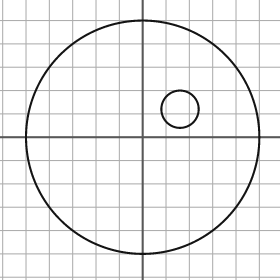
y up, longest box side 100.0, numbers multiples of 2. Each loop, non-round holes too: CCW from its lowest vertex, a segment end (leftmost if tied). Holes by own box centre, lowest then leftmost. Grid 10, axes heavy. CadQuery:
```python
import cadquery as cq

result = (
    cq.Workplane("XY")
    .moveTo(0.0, 0.0)
    .circle(50.0)
    .moveTo(16.0, 12.0)
    .circle(8.0)
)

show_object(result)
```